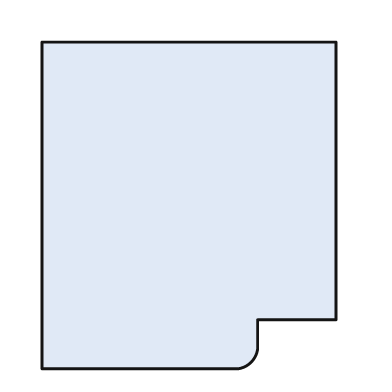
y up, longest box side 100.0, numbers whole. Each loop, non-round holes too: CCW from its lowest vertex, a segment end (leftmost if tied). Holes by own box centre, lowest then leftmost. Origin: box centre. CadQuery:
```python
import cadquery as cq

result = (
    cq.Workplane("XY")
    .moveTo(-45.0, -50.0)
    .lineTo(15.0, -50.0)
    .threePointArc((19.0, -48.0), (21.0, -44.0))
    .lineTo(21.0, -35.0)
    .lineTo(45.0, -35.0)
    .lineTo(45.0, 50.0)
    .lineTo(-45.0, 50.0)
    .close()
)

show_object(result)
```